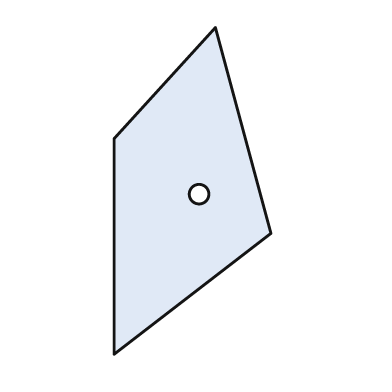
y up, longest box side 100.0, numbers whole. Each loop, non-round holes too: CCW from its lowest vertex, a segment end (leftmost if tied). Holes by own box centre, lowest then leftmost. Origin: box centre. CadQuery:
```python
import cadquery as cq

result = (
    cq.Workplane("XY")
    .moveTo(-24.0, -50.0)
    .lineTo(24.0, -13.0)
    .lineTo(7.0, 50.0)
    .lineTo(-24.0, 16.0)
    .close()
    .moveTo(2.0, -1.0)
    .circle(3.0)
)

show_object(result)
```